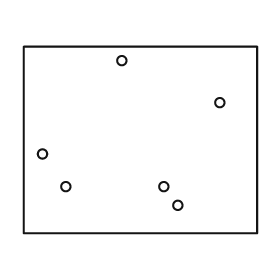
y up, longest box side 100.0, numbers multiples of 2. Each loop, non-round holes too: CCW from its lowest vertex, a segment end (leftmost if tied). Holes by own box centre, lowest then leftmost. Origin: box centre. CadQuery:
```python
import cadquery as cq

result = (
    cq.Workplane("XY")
    .moveTo(-50.0, -40.0)
    .lineTo(50.0, -40.0)
    .lineTo(50.0, 40.0)
    .lineTo(-50.0, 40.0)
    .close()
    .moveTo(16.0, -28.0)
    .circle(2.0)
    .moveTo(-32.0, -20.0)
    .circle(2.0)
    .moveTo(10.0, -20.0)
    .circle(2.0)
    .moveTo(-42.0, -6.0)
    .circle(2.0)
    .moveTo(34.0, 16.0)
    .circle(2.0)
    .moveTo(-8.0, 34.0)
    .circle(2.0)
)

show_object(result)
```